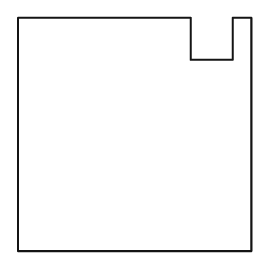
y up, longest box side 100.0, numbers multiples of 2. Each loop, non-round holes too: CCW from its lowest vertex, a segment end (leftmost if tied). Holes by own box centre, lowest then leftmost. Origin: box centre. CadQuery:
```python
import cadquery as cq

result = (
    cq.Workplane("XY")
    .moveTo(-50.0, -50.0)
    .lineTo(50.0, -50.0)
    .lineTo(50.0, 50.0)
    .lineTo(42.0, 50.0)
    .lineTo(42.0, 32.0)
    .lineTo(24.0, 32.0)
    .lineTo(24.0, 50.0)
    .lineTo(-50.0, 50.0)
    .close()
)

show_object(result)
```